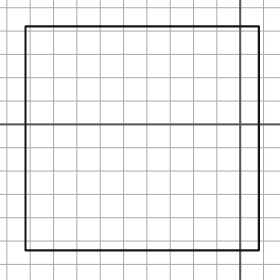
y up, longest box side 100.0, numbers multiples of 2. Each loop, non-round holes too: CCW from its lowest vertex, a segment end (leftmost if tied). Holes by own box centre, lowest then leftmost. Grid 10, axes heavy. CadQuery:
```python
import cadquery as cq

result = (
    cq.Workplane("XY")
    .moveTo(-92.0, -54.0)
    .lineTo(8.0, -54.0)
    .lineTo(8.0, 42.0)
    .lineTo(-92.0, 42.0)
    .close()
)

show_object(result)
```